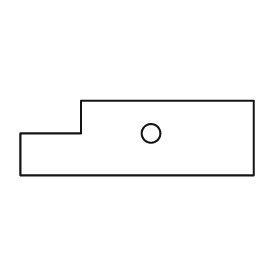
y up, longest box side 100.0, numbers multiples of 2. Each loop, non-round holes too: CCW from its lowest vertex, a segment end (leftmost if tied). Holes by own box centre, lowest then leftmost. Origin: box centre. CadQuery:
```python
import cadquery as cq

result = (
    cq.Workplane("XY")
    .moveTo(-50.0, -16.0)
    .lineTo(50.0, -16.0)
    .lineTo(50.0, 16.0)
    .lineTo(-24.0, 16.0)
    .lineTo(-24.0, 2.0)
    .lineTo(-50.0, 2.0)
    .close()
    .moveTo(6.0, 2.0)
    .circle(4.0)
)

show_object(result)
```